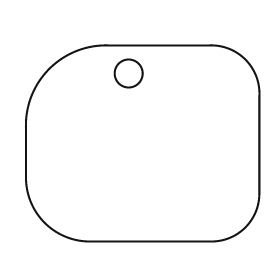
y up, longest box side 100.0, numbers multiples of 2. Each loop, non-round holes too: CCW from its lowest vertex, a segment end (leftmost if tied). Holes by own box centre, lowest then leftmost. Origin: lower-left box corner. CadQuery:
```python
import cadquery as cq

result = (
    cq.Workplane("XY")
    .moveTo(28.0, 0.0)
    .lineTo(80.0, 0.0)
    .threePointArc((94.0, 6.0), (100.0, 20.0))
    .lineTo(100.0, 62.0)
    .threePointArc((94.0, 78.0), (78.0, 84.0))
    .lineTo(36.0, 84.0)
    .threePointArc((10.0, 74.0), (0.0, 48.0))
    .lineTo(0.0, 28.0)
    .threePointArc((8.0, 8.0), (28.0, 0.0))
    .close()
    .moveTo(44.0, 72.0)
    .circle(6.0)
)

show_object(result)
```